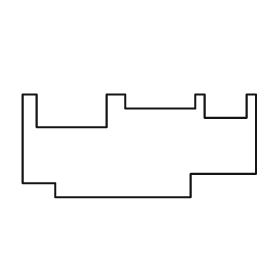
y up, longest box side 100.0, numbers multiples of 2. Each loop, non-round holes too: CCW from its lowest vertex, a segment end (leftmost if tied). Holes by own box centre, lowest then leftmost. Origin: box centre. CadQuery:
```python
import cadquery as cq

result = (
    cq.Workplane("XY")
    .moveTo(-36.0, -22.0)
    .lineTo(22.0, -22.0)
    .lineTo(22.0, -12.0)
    .lineTo(50.0, -12.0)
    .lineTo(50.0, 22.0)
    .lineTo(46.0, 22.0)
    .lineTo(46.0, 12.0)
    .lineTo(28.0, 12.0)
    .lineTo(28.0, 22.0)
    .lineTo(24.0, 22.0)
    .lineTo(24.0, 16.0)
    .lineTo(-6.0, 16.0)
    .lineTo(-6.0, 22.0)
    .lineTo(-14.0, 22.0)
    .lineTo(-14.0, 8.0)
    .lineTo(-44.0, 8.0)
    .lineTo(-44.0, 22.0)
    .lineTo(-50.0, 22.0)
    .lineTo(-50.0, -16.0)
    .lineTo(-36.0, -16.0)
    .close()
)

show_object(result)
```